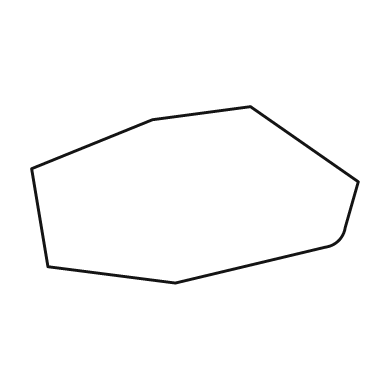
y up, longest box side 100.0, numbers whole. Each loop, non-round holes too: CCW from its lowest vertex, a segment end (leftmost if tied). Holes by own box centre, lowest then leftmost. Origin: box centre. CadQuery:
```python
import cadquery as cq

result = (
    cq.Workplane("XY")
    .moveTo(-6.0, -27.0)
    .lineTo(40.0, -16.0)
    .threePointArc((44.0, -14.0), (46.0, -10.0))
    .lineTo(50.0, 4.0)
    .lineTo(17.0, 27.0)
    .lineTo(-13.0, 23.0)
    .lineTo(-50.0, 8.0)
    .lineTo(-45.0, -22.0)
    .close()
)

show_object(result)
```